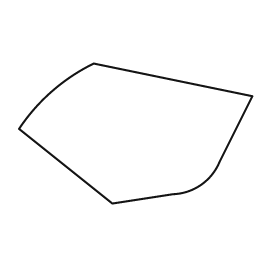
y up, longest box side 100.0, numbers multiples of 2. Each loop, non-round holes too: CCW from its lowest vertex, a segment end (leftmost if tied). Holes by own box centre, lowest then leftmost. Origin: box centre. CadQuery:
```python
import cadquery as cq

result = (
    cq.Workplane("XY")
    .moveTo(-10.0, -30.0)
    .lineTo(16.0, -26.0)
    .threePointArc((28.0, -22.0), (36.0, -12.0))
    .lineTo(50.0, 16.0)
    .lineTo(-18.0, 30.0)
    .threePointArc((-36.0, 18.0), (-50.0, 2.0))
    .close()
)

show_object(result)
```